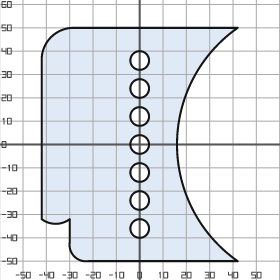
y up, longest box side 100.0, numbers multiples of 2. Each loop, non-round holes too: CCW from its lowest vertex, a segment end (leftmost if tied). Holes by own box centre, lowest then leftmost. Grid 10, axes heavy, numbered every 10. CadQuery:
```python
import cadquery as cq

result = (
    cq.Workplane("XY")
    .moveTo(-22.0, -50.0)
    .lineTo(42.0, -50.0)
    .threePointArc((16.0, 0.0), (42.0, 50.0))
    .lineTo(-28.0, 50.0)
    .threePointArc((-38.0, 46.0), (-42.0, 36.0))
    .lineTo(-42.0, -32.0)
    .threePointArc((-36.0, -34.0), (-30.0, -32.0))
    .lineTo(-30.0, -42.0)
    .threePointArc((-28.0, -48.0), (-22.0, -50.0))
    .close()
    .moveTo(0.0, -36.0)
    .circle(4.0)
    .moveTo(0.0, -24.0)
    .circle(4.0)
    .moveTo(0.0, -12.0)
    .circle(4.0)
    .moveTo(0.0, 0.0)
    .circle(4.0)
    .moveTo(0.0, 12.0)
    .circle(4.0)
    .moveTo(0.0, 24.0)
    .circle(4.0)
    .moveTo(0.0, 36.0)
    .circle(4.0)
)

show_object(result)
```